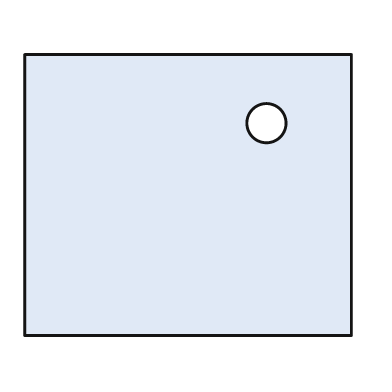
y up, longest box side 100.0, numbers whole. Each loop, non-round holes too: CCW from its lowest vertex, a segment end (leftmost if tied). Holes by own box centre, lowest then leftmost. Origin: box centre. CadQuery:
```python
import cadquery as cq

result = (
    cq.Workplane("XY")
    .moveTo(-50.0, -43.0)
    .lineTo(50.0, -43.0)
    .lineTo(50.0, 43.0)
    .lineTo(-50.0, 43.0)
    .close()
    .moveTo(24.0, 22.0)
    .circle(6.0)
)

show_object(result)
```